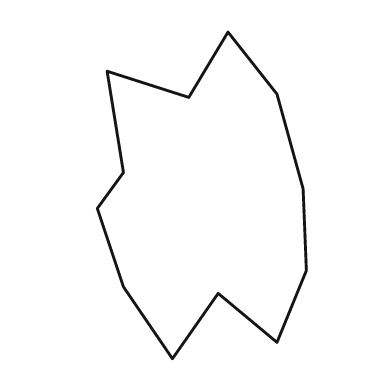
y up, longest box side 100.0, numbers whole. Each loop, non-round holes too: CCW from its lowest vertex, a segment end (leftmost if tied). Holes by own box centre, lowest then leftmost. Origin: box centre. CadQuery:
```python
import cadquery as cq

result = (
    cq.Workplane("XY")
    .moveTo(-9.0, -50.0)
    .lineTo(5.0, -30.0)
    .lineTo(23.0, -45.0)
    .lineTo(32.0, -23.0)
    .lineTo(31.0, 2.0)
    .lineTo(23.0, 31.0)
    .lineTo(8.0, 50.0)
    .lineTo(-4.0, 30.0)
    .lineTo(-29.0, 38.0)
    .lineTo(-24.0, 7.0)
    .lineTo(-32.0, -4.0)
    .lineTo(-24.0, -28.0)
    .close()
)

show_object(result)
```